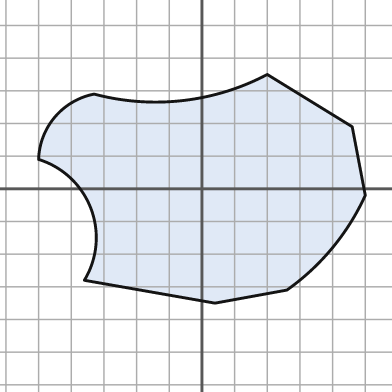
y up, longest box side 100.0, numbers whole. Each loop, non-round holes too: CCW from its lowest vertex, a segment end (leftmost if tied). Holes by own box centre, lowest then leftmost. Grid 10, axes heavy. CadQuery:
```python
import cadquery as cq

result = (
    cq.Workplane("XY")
    .moveTo(4.0, -35.0)
    .lineTo(26.0, -31.0)
    .threePointArc((40.0, -18.0), (50.0, -2.0))
    .lineTo(46.0, 19.0)
    .lineTo(20.0, 35.0)
    .threePointArc((-6.0, 27.0), (-33.0, 29.0))
    .threePointArc((-45.0, 22.0), (-50.0, 9.0))
    .threePointArc((-34.0, -6.0), (-36.0, -28.0))
    .close()
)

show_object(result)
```